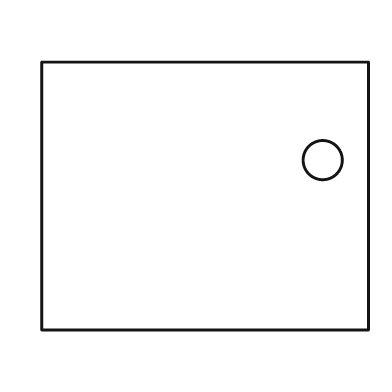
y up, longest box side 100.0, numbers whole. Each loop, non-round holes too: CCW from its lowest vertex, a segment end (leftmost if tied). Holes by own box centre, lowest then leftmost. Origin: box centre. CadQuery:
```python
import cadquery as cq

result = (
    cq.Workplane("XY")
    .moveTo(-50.0, -41.0)
    .lineTo(50.0, -41.0)
    .lineTo(50.0, 41.0)
    .lineTo(-50.0, 41.0)
    .close()
    .moveTo(36.0, 11.0)
    .circle(6.0)
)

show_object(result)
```